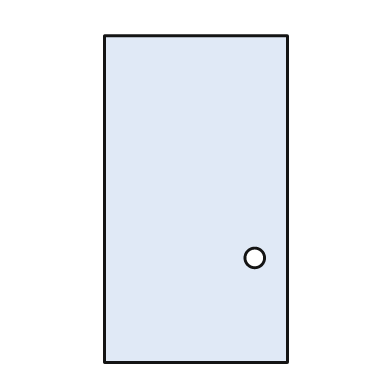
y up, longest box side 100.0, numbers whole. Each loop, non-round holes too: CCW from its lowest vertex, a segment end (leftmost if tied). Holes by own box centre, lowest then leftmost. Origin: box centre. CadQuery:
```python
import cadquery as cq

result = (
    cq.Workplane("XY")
    .moveTo(-28.0, -50.0)
    .lineTo(28.0, -50.0)
    .lineTo(28.0, 50.0)
    .lineTo(-28.0, 50.0)
    .close()
    .moveTo(18.0, -18.0)
    .circle(3.0)
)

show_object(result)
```